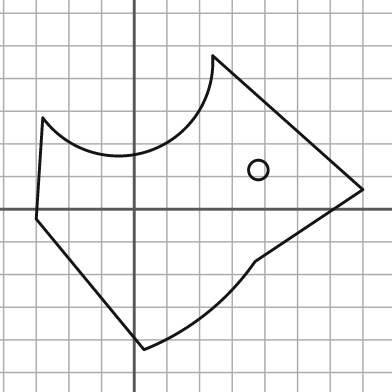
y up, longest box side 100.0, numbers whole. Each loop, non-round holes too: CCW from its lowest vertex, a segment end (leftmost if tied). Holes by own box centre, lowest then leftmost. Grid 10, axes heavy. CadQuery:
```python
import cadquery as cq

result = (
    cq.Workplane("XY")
    .moveTo(3.0, -43.0)
    .threePointArc((22.0, -32.0), (37.0, -16.0))
    .lineTo(70.0, 6.0)
    .lineTo(24.0, 47.0)
    .threePointArc((5.0, 18.0), (-28.0, 28.0))
    .lineTo(-30.0, -3.0)
    .close()
    .moveTo(38.0, 12.0)
    .circle(3.0)
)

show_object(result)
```